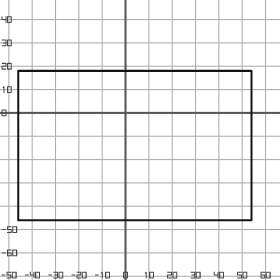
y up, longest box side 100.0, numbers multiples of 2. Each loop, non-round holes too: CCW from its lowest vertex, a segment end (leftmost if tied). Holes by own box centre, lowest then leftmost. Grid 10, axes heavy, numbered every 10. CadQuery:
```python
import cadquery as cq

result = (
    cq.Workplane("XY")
    .moveTo(-46.0, -46.0)
    .lineTo(54.0, -46.0)
    .lineTo(54.0, 18.0)
    .lineTo(-46.0, 18.0)
    .close()
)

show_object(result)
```